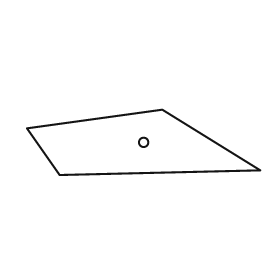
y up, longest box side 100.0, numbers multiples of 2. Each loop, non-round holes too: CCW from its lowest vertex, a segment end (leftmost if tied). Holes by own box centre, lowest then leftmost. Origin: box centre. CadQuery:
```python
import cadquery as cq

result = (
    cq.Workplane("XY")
    .moveTo(-36.0, -14.0)
    .lineTo(50.0, -12.0)
    .lineTo(8.0, 14.0)
    .lineTo(-50.0, 6.0)
    .close()
    .moveTo(0.0, 0.0)
    .circle(2.0)
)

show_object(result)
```